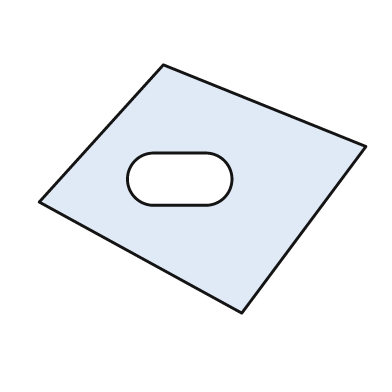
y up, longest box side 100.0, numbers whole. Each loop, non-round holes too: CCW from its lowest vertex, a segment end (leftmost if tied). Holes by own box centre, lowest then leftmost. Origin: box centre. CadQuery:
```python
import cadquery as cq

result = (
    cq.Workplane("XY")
    .moveTo(12.0, -38.0)
    .lineTo(50.0, 13.0)
    .lineTo(-12.0, 38.0)
    .lineTo(-50.0, -4.0)
    .close()
    .moveTo(-15.0, -5.0)
    .lineTo(1.0, -5.0)
    .threePointArc((9.0, 3.0), (1.0, 11.0))
    .lineTo(-15.0, 11.0)
    .threePointArc((-23.0, 3.0), (-15.0, -5.0))
    .close()
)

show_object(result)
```